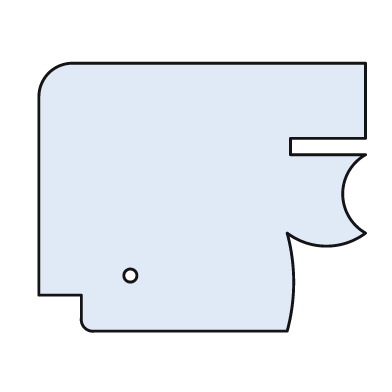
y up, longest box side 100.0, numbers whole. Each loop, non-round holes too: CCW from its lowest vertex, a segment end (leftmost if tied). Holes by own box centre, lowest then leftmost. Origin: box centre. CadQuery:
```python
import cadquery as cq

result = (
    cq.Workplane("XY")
    .moveTo(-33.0, -41.0)
    .lineTo(26.0, -41.0)
    .threePointArc((28.0, -26.0), (26.0, -11.0))
    .threePointArc((38.0, -15.0), (50.0, -11.0))
    .threePointArc((43.0, 1.0), (50.0, 13.0))
    .lineTo(27.0, 13.0)
    .lineTo(27.0, 18.0)
    .lineTo(50.0, 18.0)
    .lineTo(50.0, 41.0)
    .lineTo(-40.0, 41.0)
    .threePointArc((-47.0, 38.0), (-50.0, 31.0))
    .lineTo(-50.0, -30.0)
    .lineTo(-37.0, -30.0)
    .lineTo(-37.0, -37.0)
    .threePointArc((-36.0, -40.0), (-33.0, -41.0))
    .close()
    .moveTo(-22.0, -24.0)
    .circle(2.0)
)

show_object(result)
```